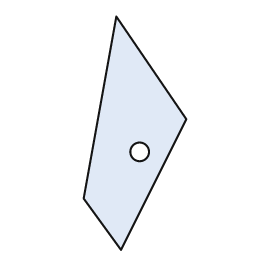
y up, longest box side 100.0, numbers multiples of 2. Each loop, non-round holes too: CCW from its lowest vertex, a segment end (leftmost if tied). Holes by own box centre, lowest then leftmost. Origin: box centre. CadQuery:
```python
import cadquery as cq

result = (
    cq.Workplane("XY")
    .moveTo(-6.0, -50.0)
    .lineTo(22.0, 6.0)
    .lineTo(-8.0, 50.0)
    .lineTo(-22.0, -28.0)
    .close()
    .moveTo(2.0, -8.0)
    .circle(4.0)
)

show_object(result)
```